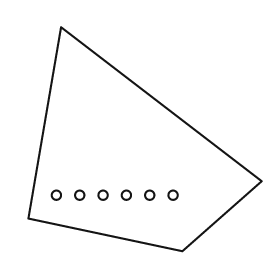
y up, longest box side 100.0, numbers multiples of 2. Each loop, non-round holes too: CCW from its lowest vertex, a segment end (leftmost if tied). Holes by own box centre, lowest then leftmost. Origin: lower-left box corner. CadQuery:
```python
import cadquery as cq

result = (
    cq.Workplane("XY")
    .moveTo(66.0, 0.0)
    .lineTo(100.0, 30.0)
    .lineTo(14.0, 96.0)
    .lineTo(0.0, 14.0)
    .close()
    .moveTo(12.0, 24.0)
    .circle(2.0)
    .moveTo(22.0, 24.0)
    .circle(2.0)
    .moveTo(32.0, 24.0)
    .circle(2.0)
    .moveTo(42.0, 24.0)
    .circle(2.0)
    .moveTo(52.0, 24.0)
    .circle(2.0)
    .moveTo(62.0, 24.0)
    .circle(2.0)
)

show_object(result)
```